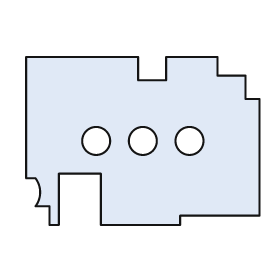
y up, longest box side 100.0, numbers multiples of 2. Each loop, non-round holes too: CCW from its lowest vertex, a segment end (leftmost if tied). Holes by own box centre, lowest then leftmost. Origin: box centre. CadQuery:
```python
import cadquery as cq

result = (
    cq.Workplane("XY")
    .moveTo(-40.0, -36.0)
    .lineTo(-36.0, -36.0)
    .lineTo(-36.0, -14.0)
    .lineTo(-18.0, -14.0)
    .lineTo(-18.0, -36.0)
    .lineTo(16.0, -36.0)
    .lineTo(16.0, -32.0)
    .lineTo(50.0, -32.0)
    .lineTo(50.0, 18.0)
    .lineTo(44.0, 18.0)
    .lineTo(44.0, 28.0)
    .lineTo(32.0, 28.0)
    .lineTo(32.0, 36.0)
    .lineTo(10.0, 36.0)
    .lineTo(10.0, 26.0)
    .lineTo(-2.0, 26.0)
    .lineTo(-2.0, 36.0)
    .lineTo(-50.0, 36.0)
    .lineTo(-50.0, -16.0)
    .lineTo(-46.0, -16.0)
    .threePointArc((-44.0, -22.0), (-46.0, -28.0))
    .lineTo(-40.0, -28.0)
    .close()
    .moveTo(-20.0, 0.0)
    .circle(6.0)
    .moveTo(0.0, 0.0)
    .circle(6.0)
    .moveTo(20.0, 0.0)
    .circle(6.0)
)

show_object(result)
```